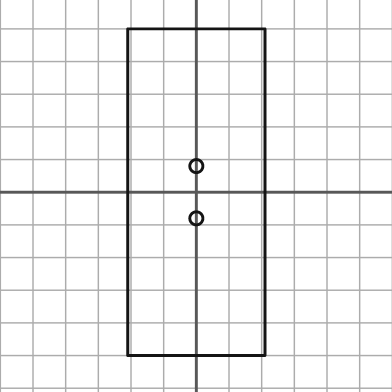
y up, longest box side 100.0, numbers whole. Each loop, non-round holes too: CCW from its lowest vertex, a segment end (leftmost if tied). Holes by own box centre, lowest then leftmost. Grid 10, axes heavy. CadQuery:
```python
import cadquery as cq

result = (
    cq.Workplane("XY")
    .moveTo(-21.0, -50.0)
    .lineTo(21.0, -50.0)
    .lineTo(21.0, 50.0)
    .lineTo(-21.0, 50.0)
    .close()
    .moveTo(0.0, -8.0)
    .circle(2.0)
    .moveTo(0.0, 8.0)
    .circle(2.0)
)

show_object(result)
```